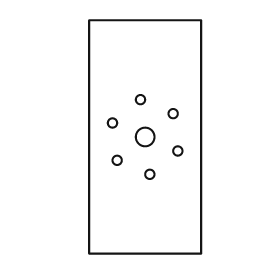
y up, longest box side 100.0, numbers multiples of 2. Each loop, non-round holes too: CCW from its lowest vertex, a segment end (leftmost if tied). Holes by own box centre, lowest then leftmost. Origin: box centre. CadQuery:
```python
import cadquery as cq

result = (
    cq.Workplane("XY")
    .moveTo(-24.0, -50.0)
    .lineTo(24.0, -50.0)
    .lineTo(24.0, 50.0)
    .lineTo(-24.0, 50.0)
    .close()
    .moveTo(2.0, -16.0)
    .circle(2.0)
    .moveTo(-12.0, -10.0)
    .circle(2.0)
    .moveTo(14.0, -6.0)
    .circle(2.0)
    .moveTo(0.0, 0.0)
    .circle(4.0)
    .moveTo(-14.0, 6.0)
    .circle(2.0)
    .moveTo(12.0, 10.0)
    .circle(2.0)
    .moveTo(-2.0, 16.0)
    .circle(2.0)
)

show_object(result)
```